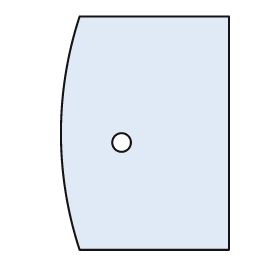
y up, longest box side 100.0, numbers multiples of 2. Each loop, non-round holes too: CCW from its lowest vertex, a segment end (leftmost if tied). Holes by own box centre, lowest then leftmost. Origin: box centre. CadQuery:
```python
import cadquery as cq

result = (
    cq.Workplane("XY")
    .moveTo(-28.0, -50.0)
    .lineTo(36.0, -50.0)
    .lineTo(36.0, 50.0)
    .lineTo(-28.0, 50.0)
    .threePointArc((-36.0, 0.0), (-28.0, -50.0))
    .close()
    .moveTo(-10.0, -4.0)
    .circle(4.0)
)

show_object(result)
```